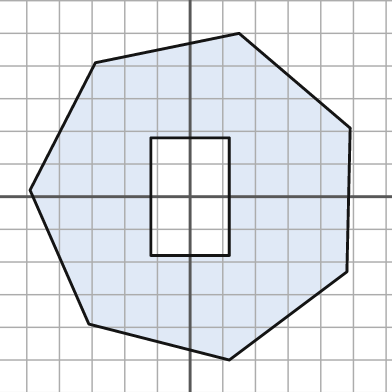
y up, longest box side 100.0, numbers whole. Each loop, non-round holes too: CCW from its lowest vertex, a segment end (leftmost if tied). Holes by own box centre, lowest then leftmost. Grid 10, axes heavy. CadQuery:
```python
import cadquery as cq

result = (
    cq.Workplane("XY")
    .moveTo(12.0, -50.0)
    .lineTo(48.0, -23.0)
    .lineTo(49.0, 21.0)
    .lineTo(15.0, 50.0)
    .lineTo(-29.0, 41.0)
    .lineTo(-49.0, 2.0)
    .lineTo(-31.0, -39.0)
    .close()
    .moveTo(-12.0, -18.0)
    .lineTo(12.0, -18.0)
    .lineTo(12.0, 18.0)
    .lineTo(-12.0, 18.0)
    .close()
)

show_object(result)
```